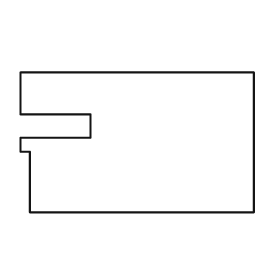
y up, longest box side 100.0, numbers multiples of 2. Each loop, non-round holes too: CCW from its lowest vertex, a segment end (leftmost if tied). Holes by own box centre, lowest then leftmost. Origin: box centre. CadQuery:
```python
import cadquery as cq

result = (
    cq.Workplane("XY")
    .moveTo(-46.0, -30.0)
    .lineTo(50.0, -30.0)
    .lineTo(50.0, 30.0)
    .lineTo(-50.0, 30.0)
    .lineTo(-50.0, 12.0)
    .lineTo(-20.0, 12.0)
    .lineTo(-20.0, 2.0)
    .lineTo(-50.0, 2.0)
    .lineTo(-50.0, -4.0)
    .lineTo(-46.0, -4.0)
    .close()
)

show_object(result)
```